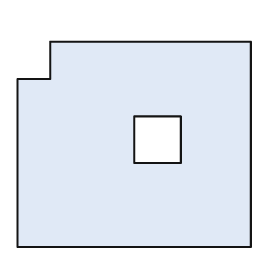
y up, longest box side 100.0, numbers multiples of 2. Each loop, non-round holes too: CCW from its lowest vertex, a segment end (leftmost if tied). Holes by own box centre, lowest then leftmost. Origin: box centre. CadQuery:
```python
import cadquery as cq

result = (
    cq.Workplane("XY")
    .moveTo(-50.0, -44.0)
    .lineTo(50.0, -44.0)
    .lineTo(50.0, 44.0)
    .lineTo(-36.0, 44.0)
    .lineTo(-36.0, 28.0)
    .lineTo(-50.0, 28.0)
    .close()
    .moveTo(0.0, -8.0)
    .lineTo(20.0, -8.0)
    .lineTo(20.0, 12.0)
    .lineTo(0.0, 12.0)
    .close()
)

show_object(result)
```